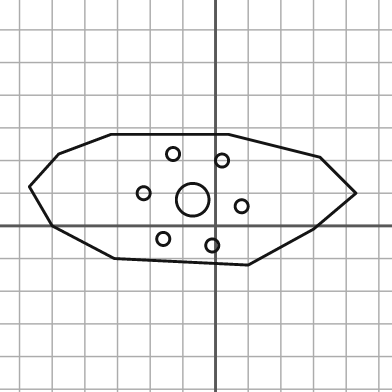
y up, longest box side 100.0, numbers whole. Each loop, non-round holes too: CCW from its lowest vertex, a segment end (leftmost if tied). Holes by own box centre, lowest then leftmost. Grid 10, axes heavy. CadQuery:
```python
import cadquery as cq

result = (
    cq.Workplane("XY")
    .moveTo(10.0, -12.0)
    .lineTo(30.0, -1.0)
    .lineTo(43.0, 10.0)
    .lineTo(32.0, 21.0)
    .lineTo(4.0, 28.0)
    .lineTo(-32.0, 28.0)
    .lineTo(-48.0, 22.0)
    .lineTo(-57.0, 12.0)
    .lineTo(-50.0, 0.0)
    .lineTo(-31.0, -10.0)
    .close()
    .moveTo(-1.0, -6.0)
    .circle(2.0)
    .moveTo(-16.0, -4.0)
    .circle(2.0)
    .moveTo(8.0, 6.0)
    .circle(2.0)
    .moveTo(-7.0, 8.0)
    .circle(5.0)
    .moveTo(-22.0, 10.0)
    .circle(2.0)
    .moveTo(2.0, 20.0)
    .circle(2.0)
    .moveTo(-13.0, 22.0)
    .circle(2.0)
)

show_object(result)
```